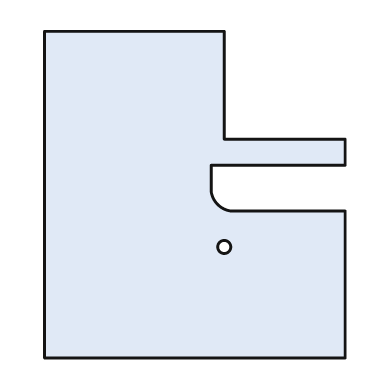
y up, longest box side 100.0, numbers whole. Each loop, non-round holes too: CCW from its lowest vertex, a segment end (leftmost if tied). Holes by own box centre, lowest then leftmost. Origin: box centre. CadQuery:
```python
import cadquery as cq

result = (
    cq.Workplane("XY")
    .moveTo(-46.0, -50.0)
    .lineTo(46.0, -50.0)
    .lineTo(46.0, -5.0)
    .lineTo(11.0, -5.0)
    .threePointArc((7.0, -3.0), (5.0, 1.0))
    .lineTo(5.0, 9.0)
    .lineTo(46.0, 9.0)
    .lineTo(46.0, 17.0)
    .lineTo(9.0, 17.0)
    .lineTo(9.0, 50.0)
    .lineTo(-46.0, 50.0)
    .close()
    .moveTo(9.0, -16.0)
    .circle(2.0)
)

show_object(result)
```